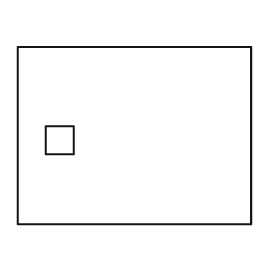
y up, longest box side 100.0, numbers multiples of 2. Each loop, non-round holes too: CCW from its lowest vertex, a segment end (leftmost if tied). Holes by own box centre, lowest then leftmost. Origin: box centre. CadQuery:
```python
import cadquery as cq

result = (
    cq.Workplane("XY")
    .moveTo(-50.0, -38.0)
    .lineTo(50.0, -38.0)
    .lineTo(50.0, 38.0)
    .lineTo(-50.0, 38.0)
    .close()
    .moveTo(-38.0, -8.0)
    .lineTo(-26.0, -8.0)
    .lineTo(-26.0, 4.0)
    .lineTo(-38.0, 4.0)
    .close()
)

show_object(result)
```